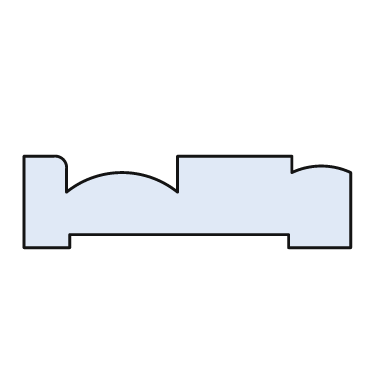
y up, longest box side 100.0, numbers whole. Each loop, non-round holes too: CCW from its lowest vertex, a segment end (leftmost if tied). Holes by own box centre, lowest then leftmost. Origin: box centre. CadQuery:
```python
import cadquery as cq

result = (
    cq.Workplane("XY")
    .moveTo(-50.0, -14.0)
    .lineTo(-36.0, -14.0)
    .lineTo(-36.0, -10.0)
    .lineTo(31.0, -10.0)
    .lineTo(31.0, -14.0)
    .lineTo(50.0, -14.0)
    .lineTo(50.0, 9.0)
    .threePointArc((41.0, 11.0), (32.0, 9.0))
    .lineTo(32.0, 14.0)
    .lineTo(-3.0, 14.0)
    .lineTo(-3.0, 3.0)
    .threePointArc((-20.0, 9.0), (-37.0, 3.0))
    .lineTo(-37.0, 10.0)
    .threePointArc((-38.0, 13.0), (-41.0, 14.0))
    .lineTo(-50.0, 14.0)
    .close()
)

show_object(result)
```